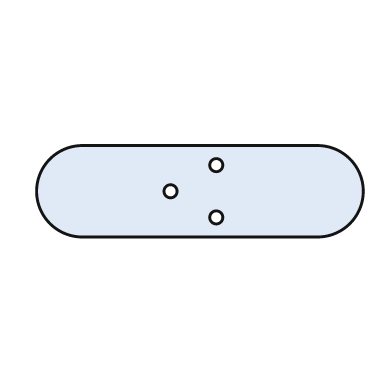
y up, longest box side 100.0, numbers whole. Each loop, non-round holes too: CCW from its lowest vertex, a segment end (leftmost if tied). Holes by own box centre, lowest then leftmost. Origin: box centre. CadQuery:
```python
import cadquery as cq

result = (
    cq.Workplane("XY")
    .moveTo(-36.0, -14.0)
    .lineTo(36.0, -14.0)
    .threePointArc((50.0, 0.0), (36.0, 14.0))
    .lineTo(-36.0, 14.0)
    .threePointArc((-50.0, 0.0), (-36.0, -14.0))
    .close()
    .moveTo(5.0, -8.0)
    .circle(2.0)
    .moveTo(-9.0, 0.0)
    .circle(2.0)
    .moveTo(5.0, 8.0)
    .circle(2.0)
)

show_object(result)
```